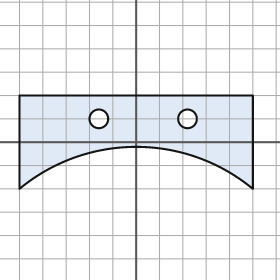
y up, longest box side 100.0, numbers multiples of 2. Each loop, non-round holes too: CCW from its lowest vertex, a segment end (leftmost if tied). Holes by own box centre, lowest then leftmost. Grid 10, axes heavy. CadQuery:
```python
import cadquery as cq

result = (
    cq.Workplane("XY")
    .moveTo(-50.0, -20.0)
    .threePointArc((0.0, -2.0), (50.0, -20.0))
    .lineTo(50.0, 20.0)
    .lineTo(-50.0, 20.0)
    .close()
    .moveTo(-16.0, 10.0)
    .circle(4.0)
    .moveTo(22.0, 10.0)
    .circle(4.0)
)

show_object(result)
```